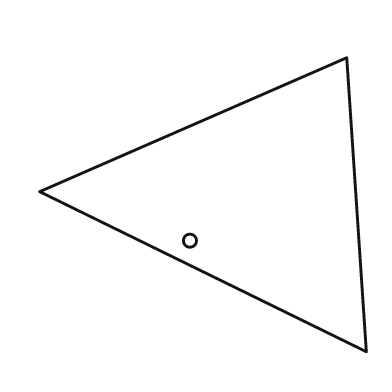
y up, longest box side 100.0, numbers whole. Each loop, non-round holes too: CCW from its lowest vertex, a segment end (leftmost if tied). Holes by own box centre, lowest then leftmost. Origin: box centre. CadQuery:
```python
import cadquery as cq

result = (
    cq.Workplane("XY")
    .moveTo(50.0, -45.0)
    .lineTo(44.0, 45.0)
    .lineTo(-50.0, 4.0)
    .close()
    .moveTo(-4.0, -11.0)
    .circle(2.0)
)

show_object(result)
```